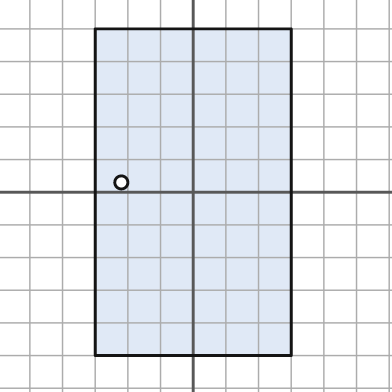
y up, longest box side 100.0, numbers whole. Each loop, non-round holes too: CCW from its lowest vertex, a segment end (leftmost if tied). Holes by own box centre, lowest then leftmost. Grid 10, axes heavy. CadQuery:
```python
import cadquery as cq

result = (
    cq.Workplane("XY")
    .moveTo(-30.0, -50.0)
    .lineTo(30.0, -50.0)
    .lineTo(30.0, 50.0)
    .lineTo(-30.0, 50.0)
    .close()
    .moveTo(-22.0, 3.0)
    .circle(2.0)
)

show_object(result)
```